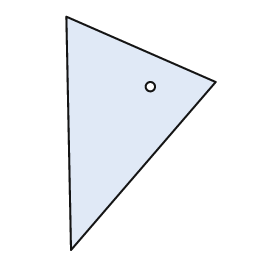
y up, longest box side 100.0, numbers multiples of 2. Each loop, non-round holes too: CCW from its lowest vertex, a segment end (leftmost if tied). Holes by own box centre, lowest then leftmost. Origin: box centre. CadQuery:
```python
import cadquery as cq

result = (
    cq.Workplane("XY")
    .moveTo(-30.0, -50.0)
    .lineTo(32.0, 22.0)
    .lineTo(-32.0, 50.0)
    .close()
    .moveTo(4.0, 20.0)
    .circle(2.0)
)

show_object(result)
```